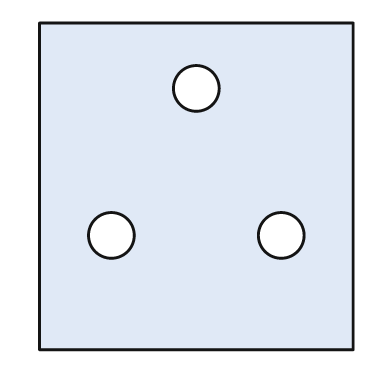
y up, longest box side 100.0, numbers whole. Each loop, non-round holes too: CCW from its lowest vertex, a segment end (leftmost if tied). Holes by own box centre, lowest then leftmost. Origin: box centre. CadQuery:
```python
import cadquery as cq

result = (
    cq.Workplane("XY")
    .moveTo(-48.0, -50.0)
    .lineTo(48.0, -50.0)
    .lineTo(48.0, 50.0)
    .lineTo(-48.0, 50.0)
    .close()
    .moveTo(-26.0, -15.0)
    .circle(7.0)
    .moveTo(26.0, -15.0)
    .circle(7.0)
    .moveTo(0.0, 30.0)
    .circle(7.0)
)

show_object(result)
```